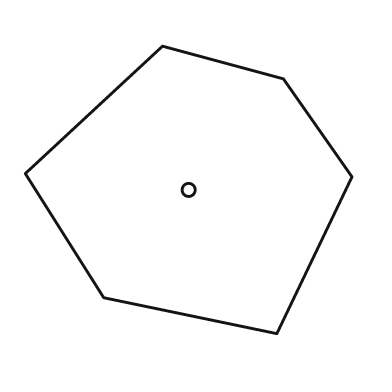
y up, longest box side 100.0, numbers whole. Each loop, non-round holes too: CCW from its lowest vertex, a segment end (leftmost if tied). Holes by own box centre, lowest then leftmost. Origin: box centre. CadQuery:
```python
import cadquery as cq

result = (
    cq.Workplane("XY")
    .moveTo(27.0, -44.0)
    .lineTo(50.0, 4.0)
    .lineTo(29.0, 34.0)
    .lineTo(-8.0, 44.0)
    .lineTo(-50.0, 5.0)
    .lineTo(-26.0, -33.0)
    .close()
    .moveTo(0.0, 0.0)
    .circle(2.0)
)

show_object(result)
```